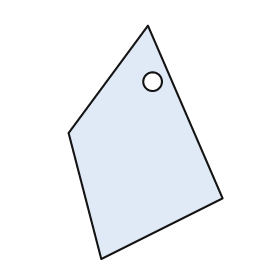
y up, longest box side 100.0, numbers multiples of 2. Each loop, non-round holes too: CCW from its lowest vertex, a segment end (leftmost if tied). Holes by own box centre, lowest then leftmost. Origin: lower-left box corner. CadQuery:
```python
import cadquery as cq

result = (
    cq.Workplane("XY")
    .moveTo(14.0, 0.0)
    .lineTo(66.0, 26.0)
    .lineTo(34.0, 100.0)
    .lineTo(0.0, 54.0)
    .close()
    .moveTo(36.0, 76.0)
    .circle(4.0)
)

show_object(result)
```